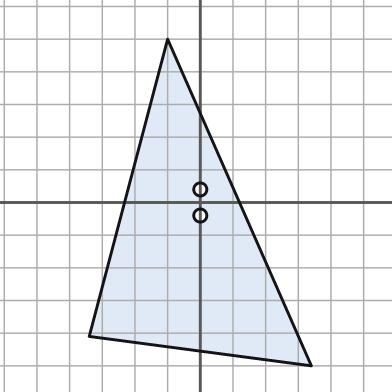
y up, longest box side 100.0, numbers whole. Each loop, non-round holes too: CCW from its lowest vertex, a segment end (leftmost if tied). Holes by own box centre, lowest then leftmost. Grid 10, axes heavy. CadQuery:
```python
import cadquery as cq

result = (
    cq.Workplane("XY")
    .moveTo(34.0, -50.0)
    .lineTo(-10.0, 50.0)
    .lineTo(-34.0, -41.0)
    .close()
    .moveTo(0.0, -4.0)
    .circle(2.0)
    .moveTo(0.0, 4.0)
    .circle(2.0)
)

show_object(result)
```